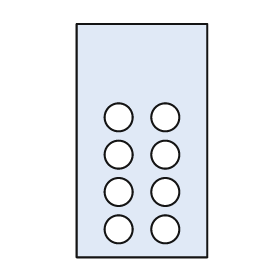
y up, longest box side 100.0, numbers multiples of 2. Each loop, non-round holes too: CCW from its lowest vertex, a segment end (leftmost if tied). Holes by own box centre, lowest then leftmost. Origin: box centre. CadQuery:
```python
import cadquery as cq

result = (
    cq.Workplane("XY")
    .moveTo(-28.0, -50.0)
    .lineTo(28.0, -50.0)
    .lineTo(28.0, 50.0)
    .lineTo(-28.0, 50.0)
    .close()
    .moveTo(-10.0, -38.0)
    .circle(6.0)
    .moveTo(10.0, -38.0)
    .circle(6.0)
    .moveTo(-10.0, -22.0)
    .circle(6.0)
    .moveTo(10.0, -22.0)
    .circle(6.0)
    .moveTo(-10.0, -6.0)
    .circle(6.0)
    .moveTo(10.0, -6.0)
    .circle(6.0)
    .moveTo(-10.0, 10.0)
    .circle(6.0)
    .moveTo(10.0, 10.0)
    .circle(6.0)
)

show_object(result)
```